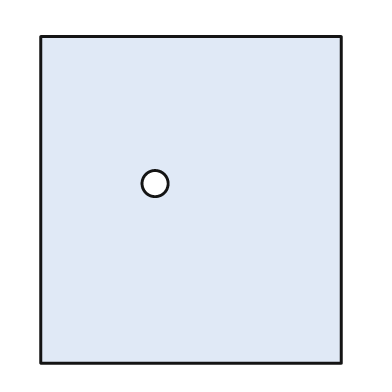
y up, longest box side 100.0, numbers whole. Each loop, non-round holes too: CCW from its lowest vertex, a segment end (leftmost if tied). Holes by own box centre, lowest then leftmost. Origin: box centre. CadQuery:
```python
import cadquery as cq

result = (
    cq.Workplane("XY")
    .moveTo(-46.0, -50.0)
    .lineTo(46.0, -50.0)
    .lineTo(46.0, 50.0)
    .lineTo(-46.0, 50.0)
    .close()
    .moveTo(-11.0, 5.0)
    .circle(4.0)
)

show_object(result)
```